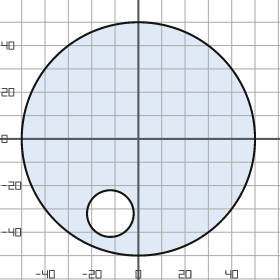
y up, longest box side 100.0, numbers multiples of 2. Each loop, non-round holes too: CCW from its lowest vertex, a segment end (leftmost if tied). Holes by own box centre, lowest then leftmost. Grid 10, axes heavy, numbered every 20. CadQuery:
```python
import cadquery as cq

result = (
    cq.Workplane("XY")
    .moveTo(0.0, 0.0)
    .circle(50.0)
    .moveTo(-12.0, -32.0)
    .circle(10.0)
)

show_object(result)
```